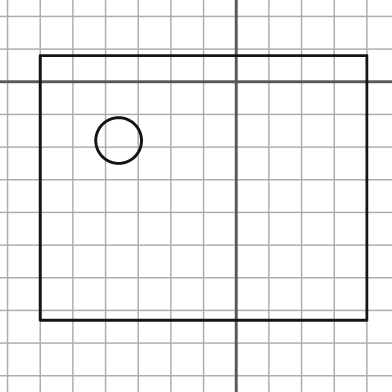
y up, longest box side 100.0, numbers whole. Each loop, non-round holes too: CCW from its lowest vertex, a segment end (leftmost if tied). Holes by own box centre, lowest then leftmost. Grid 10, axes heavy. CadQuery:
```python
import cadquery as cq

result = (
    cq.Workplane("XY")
    .moveTo(-60.0, -73.0)
    .lineTo(40.0, -73.0)
    .lineTo(40.0, 8.0)
    .lineTo(-60.0, 8.0)
    .close()
    .moveTo(-36.0, -18.0)
    .circle(7.0)
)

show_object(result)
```